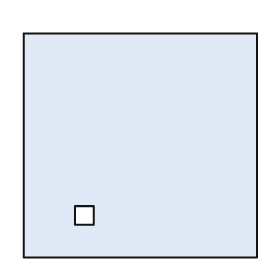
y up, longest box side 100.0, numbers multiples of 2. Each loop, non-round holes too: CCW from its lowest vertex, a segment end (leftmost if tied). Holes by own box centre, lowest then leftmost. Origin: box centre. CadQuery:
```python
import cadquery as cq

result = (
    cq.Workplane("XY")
    .moveTo(-50.0, -48.0)
    .lineTo(50.0, -48.0)
    .lineTo(50.0, 48.0)
    .lineTo(-50.0, 48.0)
    .close()
    .moveTo(-28.0, -34.0)
    .lineTo(-20.0, -34.0)
    .lineTo(-20.0, -26.0)
    .lineTo(-28.0, -26.0)
    .close()
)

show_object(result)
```